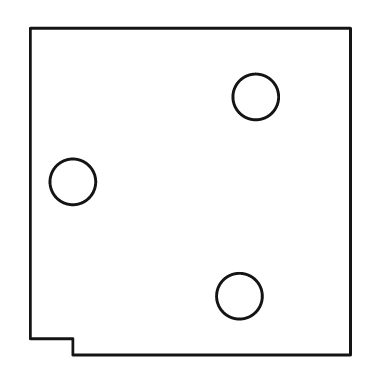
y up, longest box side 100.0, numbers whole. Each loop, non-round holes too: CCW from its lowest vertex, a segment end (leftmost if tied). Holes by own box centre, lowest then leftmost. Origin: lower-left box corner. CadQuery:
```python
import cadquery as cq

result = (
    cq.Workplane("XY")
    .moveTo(13.0, 0.0)
    .lineTo(98.0, 0.0)
    .lineTo(98.0, 100.0)
    .lineTo(0.0, 100.0)
    .lineTo(0.0, 5.0)
    .lineTo(13.0, 5.0)
    .close()
    .moveTo(64.0, 18.0)
    .circle(7.0)
    .moveTo(13.0, 53.0)
    .circle(7.0)
    .moveTo(69.0, 79.0)
    .circle(7.0)
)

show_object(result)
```